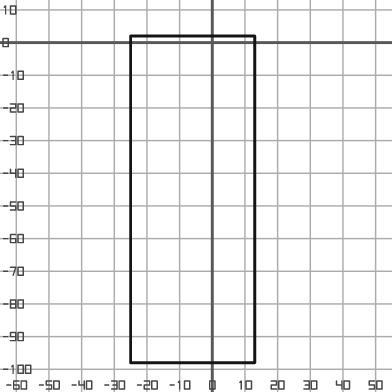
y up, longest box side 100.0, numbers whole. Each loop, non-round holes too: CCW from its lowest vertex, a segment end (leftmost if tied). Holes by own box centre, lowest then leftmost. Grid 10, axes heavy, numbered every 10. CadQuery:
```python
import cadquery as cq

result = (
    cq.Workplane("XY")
    .moveTo(-25.0, -98.0)
    .lineTo(13.0, -98.0)
    .lineTo(13.0, 2.0)
    .lineTo(-25.0, 2.0)
    .close()
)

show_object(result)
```